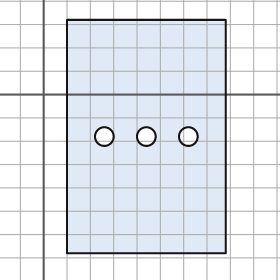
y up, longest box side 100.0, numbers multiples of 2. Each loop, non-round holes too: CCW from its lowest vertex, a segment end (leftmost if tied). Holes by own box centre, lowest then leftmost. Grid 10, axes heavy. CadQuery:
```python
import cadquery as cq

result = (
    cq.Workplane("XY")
    .moveTo(10.0, -68.0)
    .lineTo(78.0, -68.0)
    .lineTo(78.0, 32.0)
    .lineTo(10.0, 32.0)
    .close()
    .moveTo(26.0, -18.0)
    .circle(4.0)
    .moveTo(44.0, -18.0)
    .circle(4.0)
    .moveTo(62.0, -18.0)
    .circle(4.0)
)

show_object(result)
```